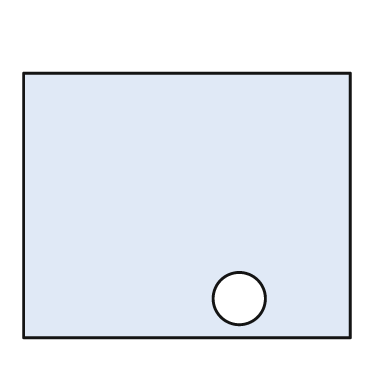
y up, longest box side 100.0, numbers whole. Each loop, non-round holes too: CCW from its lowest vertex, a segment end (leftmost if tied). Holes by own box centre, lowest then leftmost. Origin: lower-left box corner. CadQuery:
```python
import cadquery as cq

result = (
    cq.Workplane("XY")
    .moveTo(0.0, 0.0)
    .lineTo(100.0, 0.0)
    .lineTo(100.0, 81.0)
    .lineTo(0.0, 81.0)
    .close()
    .moveTo(66.0, 12.0)
    .circle(8.0)
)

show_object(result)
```